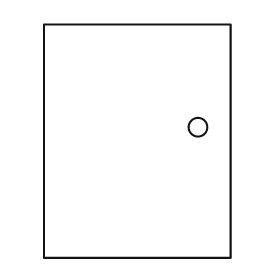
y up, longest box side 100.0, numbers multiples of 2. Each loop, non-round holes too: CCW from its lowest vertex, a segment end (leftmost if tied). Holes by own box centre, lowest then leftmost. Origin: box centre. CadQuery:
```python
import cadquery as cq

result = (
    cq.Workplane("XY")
    .moveTo(-40.0, -50.0)
    .lineTo(40.0, -50.0)
    .lineTo(40.0, 50.0)
    .lineTo(-40.0, 50.0)
    .close()
    .moveTo(26.0, 6.0)
    .circle(4.0)
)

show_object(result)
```